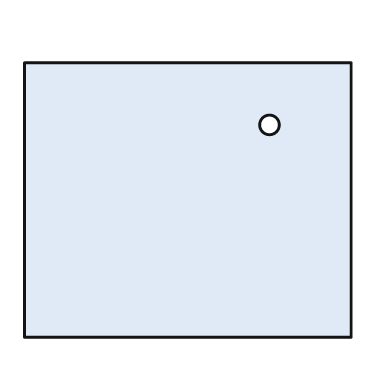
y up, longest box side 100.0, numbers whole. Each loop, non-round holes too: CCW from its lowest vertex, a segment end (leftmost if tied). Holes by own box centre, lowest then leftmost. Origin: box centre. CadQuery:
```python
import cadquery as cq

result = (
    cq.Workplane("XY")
    .moveTo(-50.0, -42.0)
    .lineTo(50.0, -42.0)
    .lineTo(50.0, 42.0)
    .lineTo(-50.0, 42.0)
    .close()
    .moveTo(25.0, 23.0)
    .circle(3.0)
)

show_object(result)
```